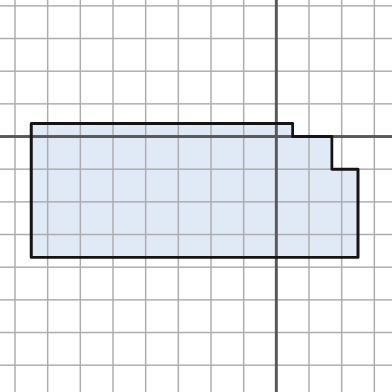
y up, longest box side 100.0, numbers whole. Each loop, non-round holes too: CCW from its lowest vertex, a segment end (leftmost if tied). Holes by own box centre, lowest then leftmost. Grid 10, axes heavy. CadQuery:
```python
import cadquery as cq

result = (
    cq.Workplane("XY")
    .moveTo(-75.0, -37.0)
    .lineTo(25.0, -37.0)
    .lineTo(25.0, -10.0)
    .lineTo(17.0, -10.0)
    .lineTo(17.0, 0.0)
    .lineTo(5.0, 0.0)
    .lineTo(5.0, 4.0)
    .lineTo(-75.0, 4.0)
    .close()
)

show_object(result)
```